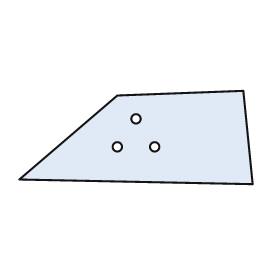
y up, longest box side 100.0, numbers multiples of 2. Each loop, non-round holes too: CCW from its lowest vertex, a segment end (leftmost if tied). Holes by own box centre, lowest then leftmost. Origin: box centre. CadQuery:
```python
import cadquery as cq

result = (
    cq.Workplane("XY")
    .moveTo(50.0, -20.0)
    .lineTo(46.0, 20.0)
    .lineTo(-8.0, 18.0)
    .lineTo(-50.0, -18.0)
    .close()
    .moveTo(-8.0, -4.0)
    .circle(2.0)
    .moveTo(8.0, -4.0)
    .circle(2.0)
    .moveTo(0.0, 8.0)
    .circle(2.0)
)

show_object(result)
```